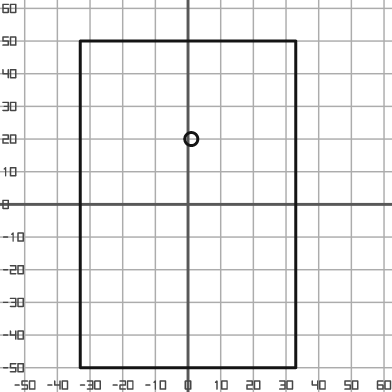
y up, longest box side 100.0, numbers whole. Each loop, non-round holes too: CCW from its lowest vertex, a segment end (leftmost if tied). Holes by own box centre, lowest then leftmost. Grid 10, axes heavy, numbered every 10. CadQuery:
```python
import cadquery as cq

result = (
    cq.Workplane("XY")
    .moveTo(-33.0, -50.0)
    .lineTo(33.0, -50.0)
    .lineTo(33.0, 50.0)
    .lineTo(-33.0, 50.0)
    .close()
    .moveTo(1.0, 20.0)
    .circle(2.0)
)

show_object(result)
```